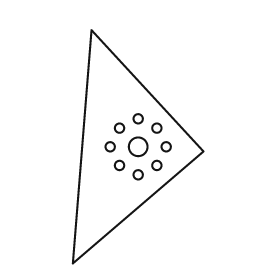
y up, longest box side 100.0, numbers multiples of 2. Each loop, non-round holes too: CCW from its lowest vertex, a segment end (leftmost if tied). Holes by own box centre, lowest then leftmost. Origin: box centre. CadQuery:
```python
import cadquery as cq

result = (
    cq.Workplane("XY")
    .moveTo(-28.0, -50.0)
    .lineTo(28.0, -2.0)
    .lineTo(-20.0, 50.0)
    .close()
    .moveTo(0.0, -12.0)
    .circle(2.0)
    .moveTo(-8.0, -8.0)
    .circle(2.0)
    .moveTo(8.0, -8.0)
    .circle(2.0)
    .moveTo(-12.0, 0.0)
    .circle(2.0)
    .moveTo(0.0, 0.0)
    .circle(4.0)
    .moveTo(12.0, 0.0)
    .circle(2.0)
    .moveTo(-8.0, 8.0)
    .circle(2.0)
    .moveTo(8.0, 8.0)
    .circle(2.0)
    .moveTo(0.0, 12.0)
    .circle(2.0)
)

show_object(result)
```